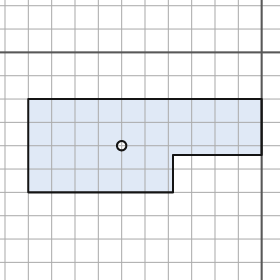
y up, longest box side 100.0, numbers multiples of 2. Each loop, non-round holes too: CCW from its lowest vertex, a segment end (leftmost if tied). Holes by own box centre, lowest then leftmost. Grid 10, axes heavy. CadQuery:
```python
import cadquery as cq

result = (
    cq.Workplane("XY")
    .moveTo(-100.0, -60.0)
    .lineTo(-38.0, -60.0)
    .lineTo(-38.0, -44.0)
    .lineTo(0.0, -44.0)
    .lineTo(0.0, -20.0)
    .lineTo(-100.0, -20.0)
    .close()
    .moveTo(-60.0, -40.0)
    .circle(2.0)
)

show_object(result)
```